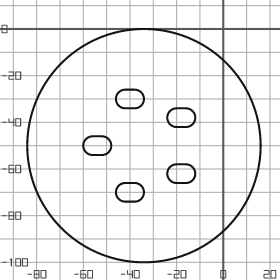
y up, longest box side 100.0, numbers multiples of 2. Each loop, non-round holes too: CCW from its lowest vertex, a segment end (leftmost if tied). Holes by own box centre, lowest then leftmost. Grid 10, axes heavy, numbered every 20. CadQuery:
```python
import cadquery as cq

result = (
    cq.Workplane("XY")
    .moveTo(-34.0, -50.0)
    .circle(50.0)
    .moveTo(-42.0, -74.0)
    .lineTo(-38.0, -74.0)
    .threePointArc((-34.0, -70.0), (-38.0, -66.0))
    .lineTo(-42.0, -66.0)
    .threePointArc((-46.0, -70.0), (-42.0, -74.0))
    .close()
    .moveTo(-20.0, -66.0)
    .lineTo(-16.0, -66.0)
    .threePointArc((-12.0, -62.0), (-16.0, -58.0))
    .lineTo(-20.0, -58.0)
    .threePointArc((-24.0, -62.0), (-20.0, -66.0))
    .close()
    .moveTo(-56.0, -54.0)
    .lineTo(-52.0, -54.0)
    .threePointArc((-48.0, -50.0), (-52.0, -46.0))
    .lineTo(-56.0, -46.0)
    .threePointArc((-60.0, -50.0), (-56.0, -54.0))
    .close()
    .moveTo(-20.0, -42.0)
    .lineTo(-16.0, -42.0)
    .threePointArc((-12.0, -38.0), (-16.0, -34.0))
    .lineTo(-20.0, -34.0)
    .threePointArc((-24.0, -38.0), (-20.0, -42.0))
    .close()
    .moveTo(-42.0, -34.0)
    .lineTo(-38.0, -34.0)
    .threePointArc((-34.0, -30.0), (-38.0, -26.0))
    .lineTo(-42.0, -26.0)
    .threePointArc((-46.0, -30.0), (-42.0, -34.0))
    .close()
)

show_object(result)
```